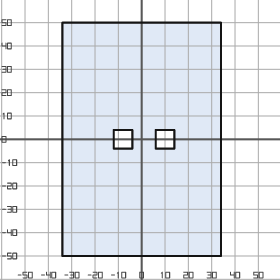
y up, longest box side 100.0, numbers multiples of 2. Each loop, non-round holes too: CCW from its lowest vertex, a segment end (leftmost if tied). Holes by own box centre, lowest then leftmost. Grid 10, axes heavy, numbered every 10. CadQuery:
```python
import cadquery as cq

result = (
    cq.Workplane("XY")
    .moveTo(-34.0, -50.0)
    .lineTo(34.0, -50.0)
    .lineTo(34.0, 50.0)
    .lineTo(-34.0, 50.0)
    .close()
    .moveTo(-12.0, -4.0)
    .lineTo(-4.0, -4.0)
    .lineTo(-4.0, 4.0)
    .lineTo(-12.0, 4.0)
    .close()
    .moveTo(6.0, -4.0)
    .lineTo(14.0, -4.0)
    .lineTo(14.0, 4.0)
    .lineTo(6.0, 4.0)
    .close()
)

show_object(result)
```